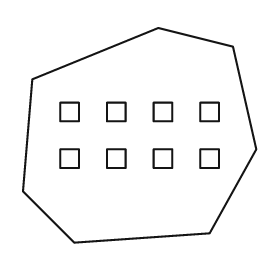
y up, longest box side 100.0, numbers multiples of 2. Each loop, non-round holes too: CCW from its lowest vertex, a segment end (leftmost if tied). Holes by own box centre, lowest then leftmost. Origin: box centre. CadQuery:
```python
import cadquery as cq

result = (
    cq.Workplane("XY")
    .moveTo(-28.0, -46.0)
    .lineTo(30.0, -42.0)
    .lineTo(50.0, -6.0)
    .lineTo(40.0, 38.0)
    .lineTo(8.0, 46.0)
    .lineTo(-46.0, 24.0)
    .lineTo(-50.0, -24.0)
    .close()
    .moveTo(-34.0, -14.0)
    .lineTo(-26.0, -14.0)
    .lineTo(-26.0, -6.0)
    .lineTo(-34.0, -6.0)
    .close()
    .moveTo(-14.0, -14.0)
    .lineTo(-6.0, -14.0)
    .lineTo(-6.0, -6.0)
    .lineTo(-14.0, -6.0)
    .close()
    .moveTo(6.0, -14.0)
    .lineTo(14.0, -14.0)
    .lineTo(14.0, -6.0)
    .lineTo(6.0, -6.0)
    .close()
    .moveTo(26.0, -14.0)
    .lineTo(34.0, -14.0)
    .lineTo(34.0, -6.0)
    .lineTo(26.0, -6.0)
    .close()
    .moveTo(-34.0, 6.0)
    .lineTo(-26.0, 6.0)
    .lineTo(-26.0, 14.0)
    .lineTo(-34.0, 14.0)
    .close()
    .moveTo(-14.0, 6.0)
    .lineTo(-6.0, 6.0)
    .lineTo(-6.0, 14.0)
    .lineTo(-14.0, 14.0)
    .close()
    .moveTo(6.0, 6.0)
    .lineTo(14.0, 6.0)
    .lineTo(14.0, 14.0)
    .lineTo(6.0, 14.0)
    .close()
    .moveTo(26.0, 6.0)
    .lineTo(34.0, 6.0)
    .lineTo(34.0, 14.0)
    .lineTo(26.0, 14.0)
    .close()
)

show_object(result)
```